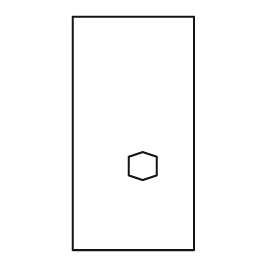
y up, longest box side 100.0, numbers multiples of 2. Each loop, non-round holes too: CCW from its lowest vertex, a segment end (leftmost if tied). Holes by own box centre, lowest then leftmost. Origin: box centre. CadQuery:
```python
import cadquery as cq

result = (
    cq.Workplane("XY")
    .moveTo(-26.0, -50.0)
    .lineTo(26.0, -50.0)
    .lineTo(26.0, 50.0)
    .lineTo(-26.0, 50.0)
    .close()
    .moveTo(4.0, -20.0)
    .lineTo(10.0, -18.0)
    .lineTo(10.0, -10.0)
    .lineTo(4.0, -8.0)
    .lineTo(-2.0, -10.0)
    .lineTo(-2.0, -18.0)
    .close()
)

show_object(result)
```